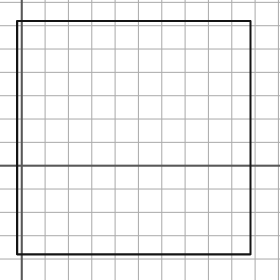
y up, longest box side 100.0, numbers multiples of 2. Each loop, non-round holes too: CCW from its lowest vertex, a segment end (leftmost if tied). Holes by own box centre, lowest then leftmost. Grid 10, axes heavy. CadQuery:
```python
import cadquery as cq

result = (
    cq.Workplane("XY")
    .moveTo(-2.0, -38.0)
    .lineTo(98.0, -38.0)
    .lineTo(98.0, 62.0)
    .lineTo(-2.0, 62.0)
    .close()
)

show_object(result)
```